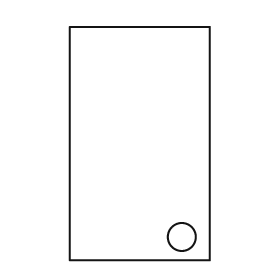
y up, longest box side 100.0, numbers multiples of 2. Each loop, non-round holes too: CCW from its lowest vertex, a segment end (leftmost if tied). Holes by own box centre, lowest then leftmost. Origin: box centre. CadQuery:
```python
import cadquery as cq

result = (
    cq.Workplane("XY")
    .moveTo(-30.0, -50.0)
    .lineTo(30.0, -50.0)
    .lineTo(30.0, 50.0)
    .lineTo(-30.0, 50.0)
    .close()
    .moveTo(18.0, -40.0)
    .circle(6.0)
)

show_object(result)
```